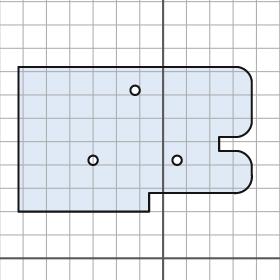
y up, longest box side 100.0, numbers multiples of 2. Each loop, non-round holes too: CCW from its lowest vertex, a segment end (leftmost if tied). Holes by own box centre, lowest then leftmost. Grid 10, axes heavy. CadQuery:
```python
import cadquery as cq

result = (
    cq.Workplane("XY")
    .moveTo(-62.0, 20.0)
    .lineTo(-6.0, 20.0)
    .lineTo(-6.0, 28.0)
    .lineTo(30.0, 28.0)
    .threePointArc((36.0, 30.0), (38.0, 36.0))
    .lineTo(38.0, 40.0)
    .threePointArc((36.0, 44.0), (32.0, 46.0))
    .lineTo(24.0, 46.0)
    .lineTo(24.0, 52.0)
    .lineTo(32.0, 52.0)
    .threePointArc((36.0, 54.0), (38.0, 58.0))
    .lineTo(38.0, 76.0)
    .threePointArc((36.0, 80.0), (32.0, 82.0))
    .lineTo(-62.0, 82.0)
    .close()
    .moveTo(-30.0, 42.0)
    .circle(2.0)
    .moveTo(6.0, 42.0)
    .circle(2.0)
    .moveTo(-12.0, 72.0)
    .circle(2.0)
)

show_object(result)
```